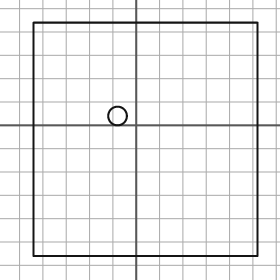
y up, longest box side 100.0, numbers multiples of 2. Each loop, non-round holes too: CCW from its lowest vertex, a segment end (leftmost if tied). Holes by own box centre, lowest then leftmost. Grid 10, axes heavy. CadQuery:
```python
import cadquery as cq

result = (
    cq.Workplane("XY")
    .moveTo(-44.0, -56.0)
    .lineTo(52.0, -56.0)
    .lineTo(52.0, 44.0)
    .lineTo(-44.0, 44.0)
    .close()
    .moveTo(-8.0, 4.0)
    .circle(4.0)
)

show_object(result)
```